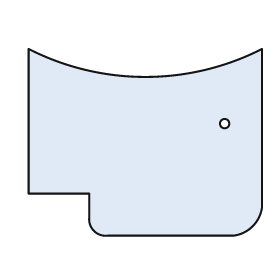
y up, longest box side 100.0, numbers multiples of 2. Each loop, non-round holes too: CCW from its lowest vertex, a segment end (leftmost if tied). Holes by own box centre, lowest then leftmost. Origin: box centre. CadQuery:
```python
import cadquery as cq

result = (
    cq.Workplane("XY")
    .moveTo(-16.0, -40.0)
    .lineTo(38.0, -40.0)
    .threePointArc((46.0, -36.0), (50.0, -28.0))
    .lineTo(50.0, 40.0)
    .threePointArc((0.0, 28.0), (-50.0, 40.0))
    .lineTo(-50.0, -22.0)
    .lineTo(-24.0, -22.0)
    .lineTo(-24.0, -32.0)
    .threePointArc((-22.0, -38.0), (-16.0, -40.0))
    .close()
    .moveTo(34.0, 8.0)
    .circle(2.0)
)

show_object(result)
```